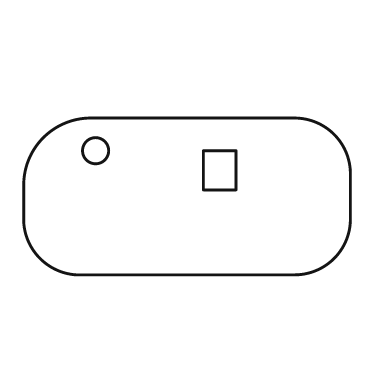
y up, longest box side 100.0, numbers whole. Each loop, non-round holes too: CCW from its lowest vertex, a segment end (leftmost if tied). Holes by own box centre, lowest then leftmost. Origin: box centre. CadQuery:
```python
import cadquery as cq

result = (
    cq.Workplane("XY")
    .moveTo(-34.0, -24.0)
    .lineTo(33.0, -24.0)
    .threePointArc((45.0, -19.0), (50.0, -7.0))
    .lineTo(50.0, 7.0)
    .threePointArc((45.0, 19.0), (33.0, 24.0))
    .lineTo(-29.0, 24.0)
    .threePointArc((-44.0, 18.0), (-50.0, 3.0))
    .lineTo(-50.0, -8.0)
    .threePointArc((-45.0, -19.0), (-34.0, -24.0))
    .close()
    .moveTo(5.0, 2.0)
    .lineTo(15.0, 2.0)
    .lineTo(15.0, 14.0)
    .lineTo(5.0, 14.0)
    .close()
    .moveTo(-28.0, 14.0)
    .circle(4.0)
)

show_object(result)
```